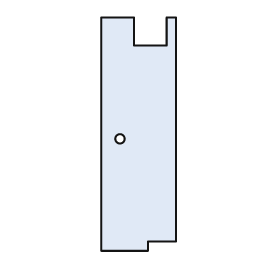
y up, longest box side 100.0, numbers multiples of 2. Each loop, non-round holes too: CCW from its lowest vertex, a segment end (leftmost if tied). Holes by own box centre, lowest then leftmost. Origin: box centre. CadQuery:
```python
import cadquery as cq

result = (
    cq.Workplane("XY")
    .moveTo(-16.0, -50.0)
    .lineTo(4.0, -50.0)
    .lineTo(4.0, -46.0)
    .lineTo(16.0, -46.0)
    .lineTo(16.0, 50.0)
    .lineTo(12.0, 50.0)
    .lineTo(12.0, 38.0)
    .lineTo(-2.0, 38.0)
    .lineTo(-2.0, 50.0)
    .lineTo(-16.0, 50.0)
    .close()
    .moveTo(-8.0, -2.0)
    .circle(2.0)
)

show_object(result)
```